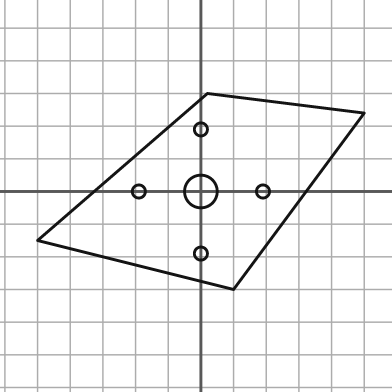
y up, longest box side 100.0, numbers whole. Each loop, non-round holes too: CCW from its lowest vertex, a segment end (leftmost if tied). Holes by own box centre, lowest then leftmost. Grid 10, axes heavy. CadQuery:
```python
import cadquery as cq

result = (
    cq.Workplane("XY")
    .moveTo(10.0, -30.0)
    .lineTo(50.0, 24.0)
    .lineTo(2.0, 30.0)
    .lineTo(-50.0, -15.0)
    .close()
    .moveTo(0.0, -19.0)
    .circle(2.0)
    .moveTo(-19.0, 0.0)
    .circle(2.0)
    .moveTo(0.0, 0.0)
    .circle(5.0)
    .moveTo(19.0, 0.0)
    .circle(2.0)
    .moveTo(0.0, 19.0)
    .circle(2.0)
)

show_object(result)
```